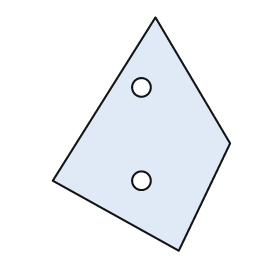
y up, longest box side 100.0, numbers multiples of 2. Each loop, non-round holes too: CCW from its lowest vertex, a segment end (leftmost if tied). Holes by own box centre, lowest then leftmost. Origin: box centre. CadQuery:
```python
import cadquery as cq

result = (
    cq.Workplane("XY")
    .moveTo(16.0, -50.0)
    .lineTo(38.0, -4.0)
    .lineTo(6.0, 50.0)
    .lineTo(-38.0, -20.0)
    .close()
    .moveTo(0.0, -20.0)
    .circle(4.0)
    .moveTo(0.0, 20.0)
    .circle(4.0)
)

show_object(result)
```